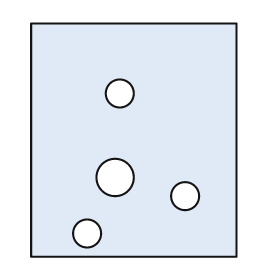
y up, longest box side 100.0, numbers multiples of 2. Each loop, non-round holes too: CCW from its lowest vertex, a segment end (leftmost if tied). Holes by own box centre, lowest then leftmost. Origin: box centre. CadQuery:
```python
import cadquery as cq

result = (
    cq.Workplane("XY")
    .moveTo(-44.0, -50.0)
    .lineTo(44.0, -50.0)
    .lineTo(44.0, 50.0)
    .lineTo(-44.0, 50.0)
    .close()
    .moveTo(-20.0, -40.0)
    .circle(6.0)
    .moveTo(22.0, -24.0)
    .circle(6.0)
    .moveTo(-8.0, -16.0)
    .circle(8.0)
    .moveTo(-6.0, 20.0)
    .circle(6.0)
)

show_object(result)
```